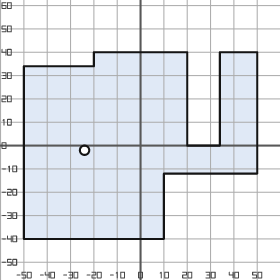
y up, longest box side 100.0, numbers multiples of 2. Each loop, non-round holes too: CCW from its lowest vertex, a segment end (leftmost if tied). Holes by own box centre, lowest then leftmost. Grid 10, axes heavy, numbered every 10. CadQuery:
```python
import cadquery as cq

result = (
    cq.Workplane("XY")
    .moveTo(-50.0, -40.0)
    .lineTo(10.0, -40.0)
    .lineTo(10.0, -12.0)
    .lineTo(50.0, -12.0)
    .lineTo(50.0, 40.0)
    .lineTo(34.0, 40.0)
    .lineTo(34.0, 0.0)
    .lineTo(20.0, 0.0)
    .lineTo(20.0, 40.0)
    .lineTo(-20.0, 40.0)
    .lineTo(-20.0, 34.0)
    .lineTo(-50.0, 34.0)
    .close()
    .moveTo(-24.0, -2.0)
    .circle(2.0)
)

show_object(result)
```